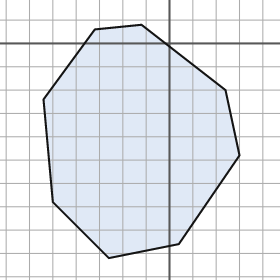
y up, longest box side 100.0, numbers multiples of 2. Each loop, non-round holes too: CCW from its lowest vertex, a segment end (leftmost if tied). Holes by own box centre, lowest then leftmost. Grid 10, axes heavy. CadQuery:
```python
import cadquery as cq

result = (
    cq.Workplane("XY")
    .moveTo(-26.0, -92.0)
    .lineTo(4.0, -86.0)
    .lineTo(30.0, -48.0)
    .lineTo(24.0, -20.0)
    .lineTo(-12.0, 8.0)
    .lineTo(-32.0, 6.0)
    .lineTo(-54.0, -24.0)
    .lineTo(-50.0, -68.0)
    .close()
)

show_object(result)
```